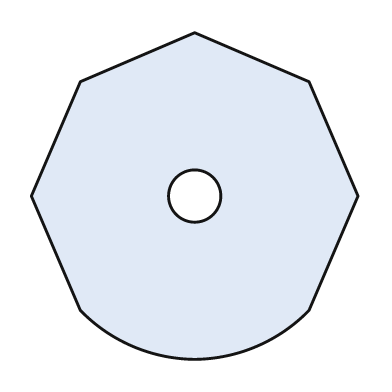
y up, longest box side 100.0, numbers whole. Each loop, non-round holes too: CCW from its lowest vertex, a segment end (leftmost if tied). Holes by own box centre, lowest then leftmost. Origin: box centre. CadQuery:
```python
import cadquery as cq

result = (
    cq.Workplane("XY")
    .moveTo(0.0, -50.0)
    .threePointArc((19.0, -46.0), (35.0, -35.0))
    .lineTo(50.0, 0.0)
    .lineTo(35.0, 35.0)
    .lineTo(0.0, 50.0)
    .lineTo(-35.0, 35.0)
    .lineTo(-50.0, 0.0)
    .lineTo(-35.0, -35.0)
    .threePointArc((-19.0, -46.0), (0.0, -50.0))
    .close()
    .moveTo(0.0, 0.0)
    .circle(8.0)
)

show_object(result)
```